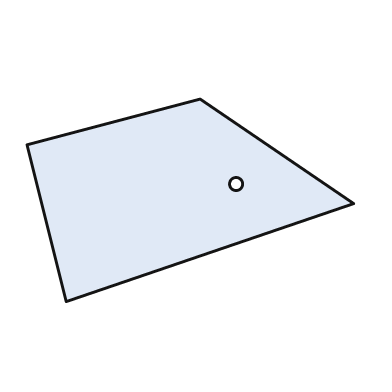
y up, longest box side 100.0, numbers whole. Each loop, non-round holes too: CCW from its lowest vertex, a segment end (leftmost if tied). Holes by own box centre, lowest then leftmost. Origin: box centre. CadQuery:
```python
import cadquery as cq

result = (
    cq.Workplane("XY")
    .moveTo(-38.0, -31.0)
    .lineTo(50.0, -1.0)
    .lineTo(3.0, 31.0)
    .lineTo(-50.0, 17.0)
    .close()
    .moveTo(14.0, 5.0)
    .circle(2.0)
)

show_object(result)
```